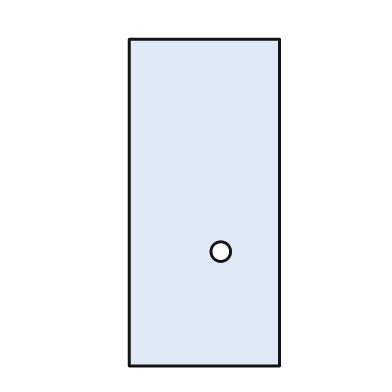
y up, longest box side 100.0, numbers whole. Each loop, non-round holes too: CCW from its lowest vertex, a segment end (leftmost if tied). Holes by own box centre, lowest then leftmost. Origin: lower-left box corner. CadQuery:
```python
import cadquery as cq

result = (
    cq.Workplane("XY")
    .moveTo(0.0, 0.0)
    .lineTo(46.0, 0.0)
    .lineTo(46.0, 100.0)
    .lineTo(0.0, 100.0)
    .close()
    .moveTo(28.0, 35.0)
    .circle(3.0)
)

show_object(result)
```